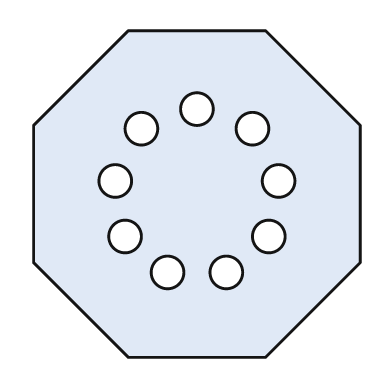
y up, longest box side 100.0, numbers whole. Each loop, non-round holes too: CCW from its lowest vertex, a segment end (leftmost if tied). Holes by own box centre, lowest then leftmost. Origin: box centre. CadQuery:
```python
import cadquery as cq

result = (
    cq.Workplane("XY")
    .moveTo(-21.0, -50.0)
    .lineTo(21.0, -50.0)
    .lineTo(50.0, -21.0)
    .lineTo(50.0, 21.0)
    .lineTo(21.0, 50.0)
    .lineTo(-21.0, 50.0)
    .lineTo(-50.0, 21.0)
    .lineTo(-50.0, -21.0)
    .close()
    .moveTo(-9.0, -24.0)
    .circle(5.0)
    .moveTo(9.0, -24.0)
    .circle(5.0)
    .moveTo(-22.0, -13.0)
    .circle(5.0)
    .moveTo(22.0, -13.0)
    .circle(5.0)
    .moveTo(-25.0, 4.0)
    .circle(5.0)
    .moveTo(25.0, 4.0)
    .circle(5.0)
    .moveTo(-17.0, 20.0)
    .circle(5.0)
    .moveTo(17.0, 20.0)
    .circle(5.0)
    .moveTo(0.0, 26.0)
    .circle(5.0)
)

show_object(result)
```